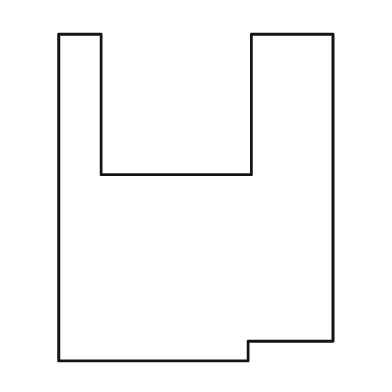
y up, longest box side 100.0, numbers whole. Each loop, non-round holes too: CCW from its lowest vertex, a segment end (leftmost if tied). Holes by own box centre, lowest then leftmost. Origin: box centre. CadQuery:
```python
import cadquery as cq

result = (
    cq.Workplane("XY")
    .moveTo(-42.0, -50.0)
    .lineTo(16.0, -50.0)
    .lineTo(16.0, -44.0)
    .lineTo(42.0, -44.0)
    .lineTo(42.0, 50.0)
    .lineTo(17.0, 50.0)
    .lineTo(17.0, 7.0)
    .lineTo(-29.0, 7.0)
    .lineTo(-29.0, 50.0)
    .lineTo(-42.0, 50.0)
    .close()
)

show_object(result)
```